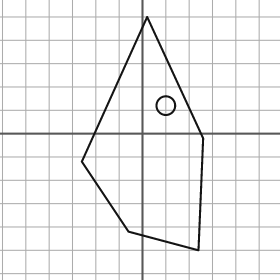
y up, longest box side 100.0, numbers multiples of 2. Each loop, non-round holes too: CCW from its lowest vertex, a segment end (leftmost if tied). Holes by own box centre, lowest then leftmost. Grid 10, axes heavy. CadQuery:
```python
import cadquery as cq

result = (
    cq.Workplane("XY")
    .moveTo(24.0, -50.0)
    .lineTo(26.0, -2.0)
    .lineTo(2.0, 50.0)
    .lineTo(-26.0, -12.0)
    .lineTo(-6.0, -42.0)
    .close()
    .moveTo(10.0, 12.0)
    .circle(4.0)
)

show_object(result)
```